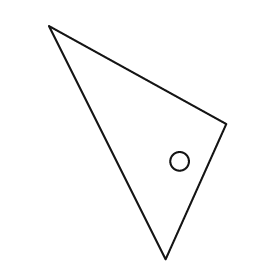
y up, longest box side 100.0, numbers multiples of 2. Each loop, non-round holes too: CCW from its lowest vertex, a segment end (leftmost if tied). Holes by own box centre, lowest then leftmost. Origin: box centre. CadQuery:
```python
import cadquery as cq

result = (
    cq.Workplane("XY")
    .moveTo(12.0, -50.0)
    .lineTo(38.0, 8.0)
    .lineTo(-38.0, 50.0)
    .close()
    .moveTo(18.0, -8.0)
    .circle(4.0)
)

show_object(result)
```